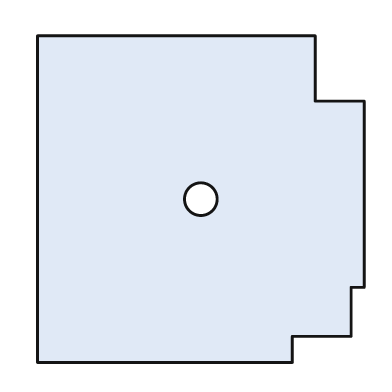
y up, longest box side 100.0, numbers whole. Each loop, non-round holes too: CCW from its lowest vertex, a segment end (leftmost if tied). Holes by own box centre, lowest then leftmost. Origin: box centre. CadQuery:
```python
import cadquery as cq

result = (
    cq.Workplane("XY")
    .moveTo(-50.0, -50.0)
    .lineTo(28.0, -50.0)
    .lineTo(28.0, -42.0)
    .lineTo(46.0, -42.0)
    .lineTo(46.0, -27.0)
    .lineTo(50.0, -27.0)
    .lineTo(50.0, 30.0)
    .lineTo(35.0, 30.0)
    .lineTo(35.0, 50.0)
    .lineTo(-50.0, 50.0)
    .close()
    .moveTo(0.0, 0.0)
    .circle(5.0)
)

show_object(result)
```